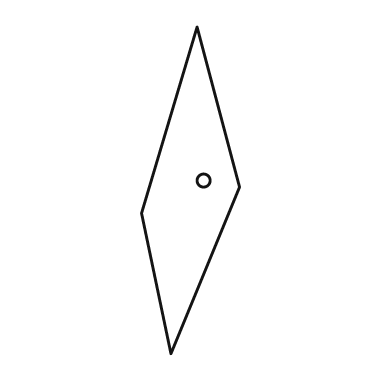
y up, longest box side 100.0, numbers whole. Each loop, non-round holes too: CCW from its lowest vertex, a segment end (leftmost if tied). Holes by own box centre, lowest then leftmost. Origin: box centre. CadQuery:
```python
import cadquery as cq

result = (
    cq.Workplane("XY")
    .moveTo(-6.0, -50.0)
    .lineTo(15.0, 1.0)
    .lineTo(2.0, 50.0)
    .lineTo(-15.0, -7.0)
    .close()
    .moveTo(4.0, 3.0)
    .circle(2.0)
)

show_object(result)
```